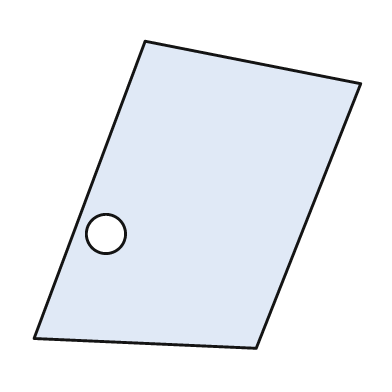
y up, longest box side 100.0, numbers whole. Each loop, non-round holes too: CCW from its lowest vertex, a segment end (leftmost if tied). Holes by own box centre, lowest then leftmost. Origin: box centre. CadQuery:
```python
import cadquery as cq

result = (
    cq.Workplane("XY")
    .moveTo(18.0, -47.0)
    .lineTo(50.0, 34.0)
    .lineTo(-16.0, 47.0)
    .lineTo(-50.0, -44.0)
    .close()
    .moveTo(-28.0, -12.0)
    .circle(6.0)
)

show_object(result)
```